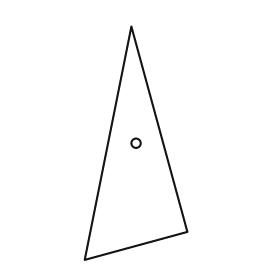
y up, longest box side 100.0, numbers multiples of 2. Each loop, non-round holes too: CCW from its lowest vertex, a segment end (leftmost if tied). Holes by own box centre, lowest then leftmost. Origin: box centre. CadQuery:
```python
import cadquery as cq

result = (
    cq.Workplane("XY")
    .moveTo(-22.0, -50.0)
    .lineTo(22.0, -38.0)
    .lineTo(-2.0, 50.0)
    .close()
    .moveTo(0.0, 0.0)
    .circle(2.0)
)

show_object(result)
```